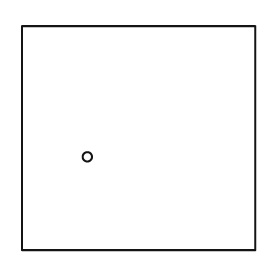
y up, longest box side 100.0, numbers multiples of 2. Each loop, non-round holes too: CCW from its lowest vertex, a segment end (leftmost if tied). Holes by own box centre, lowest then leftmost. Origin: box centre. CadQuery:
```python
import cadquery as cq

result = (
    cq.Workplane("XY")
    .moveTo(-50.0, -48.0)
    .lineTo(50.0, -48.0)
    .lineTo(50.0, 48.0)
    .lineTo(-50.0, 48.0)
    .close()
    .moveTo(-22.0, -8.0)
    .circle(2.0)
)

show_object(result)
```